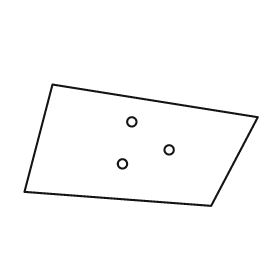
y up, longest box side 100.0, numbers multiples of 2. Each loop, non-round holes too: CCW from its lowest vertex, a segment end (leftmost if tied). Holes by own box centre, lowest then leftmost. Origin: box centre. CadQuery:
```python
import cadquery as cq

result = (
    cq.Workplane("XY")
    .moveTo(30.0, -26.0)
    .lineTo(50.0, 12.0)
    .lineTo(-38.0, 26.0)
    .lineTo(-50.0, -20.0)
    .close()
    .moveTo(-8.0, -8.0)
    .circle(2.0)
    .moveTo(12.0, -2.0)
    .circle(2.0)
    .moveTo(-4.0, 10.0)
    .circle(2.0)
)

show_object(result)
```